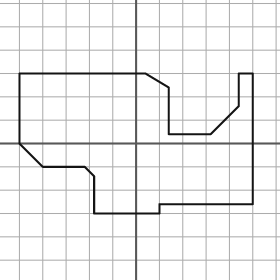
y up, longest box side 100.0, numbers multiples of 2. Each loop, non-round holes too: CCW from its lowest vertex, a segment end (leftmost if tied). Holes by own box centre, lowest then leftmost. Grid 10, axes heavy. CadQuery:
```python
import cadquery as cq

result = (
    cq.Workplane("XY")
    .moveTo(-18.0, -30.0)
    .lineTo(10.0, -30.0)
    .lineTo(10.0, -26.0)
    .lineTo(50.0, -26.0)
    .lineTo(50.0, 30.0)
    .lineTo(44.0, 30.0)
    .lineTo(44.0, 16.0)
    .lineTo(32.0, 4.0)
    .lineTo(14.0, 4.0)
    .lineTo(14.0, 24.0)
    .lineTo(4.0, 30.0)
    .lineTo(-50.0, 30.0)
    .lineTo(-50.0, 0.0)
    .lineTo(-40.0, -10.0)
    .lineTo(-22.0, -10.0)
    .lineTo(-18.0, -14.0)
    .close()
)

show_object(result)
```